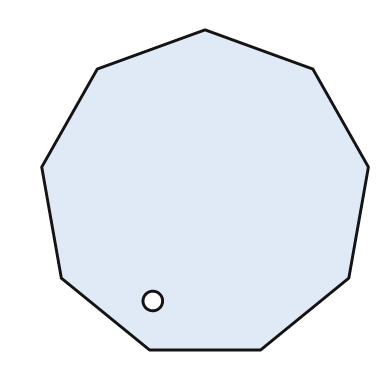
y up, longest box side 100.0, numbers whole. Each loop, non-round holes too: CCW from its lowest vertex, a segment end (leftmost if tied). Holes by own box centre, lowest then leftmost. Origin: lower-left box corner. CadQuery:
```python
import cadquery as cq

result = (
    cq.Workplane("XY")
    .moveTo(33.0, 0.0)
    .lineTo(67.0, 0.0)
    .lineTo(94.0, 22.0)
    .lineTo(100.0, 56.0)
    .lineTo(83.0, 86.0)
    .lineTo(50.0, 98.0)
    .lineTo(17.0, 86.0)
    .lineTo(0.0, 56.0)
    .lineTo(6.0, 22.0)
    .close()
    .moveTo(34.0, 15.0)
    .circle(3.0)
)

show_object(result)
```